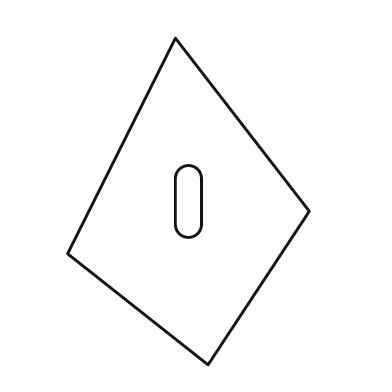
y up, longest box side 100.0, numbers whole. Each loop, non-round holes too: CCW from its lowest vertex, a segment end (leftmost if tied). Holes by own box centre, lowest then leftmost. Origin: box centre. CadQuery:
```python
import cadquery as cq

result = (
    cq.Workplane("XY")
    .moveTo(6.0, -50.0)
    .lineTo(37.0, -3.0)
    .lineTo(-4.0, 50.0)
    .lineTo(-37.0, -16.0)
    .close()
    .moveTo(-4.0, -7.0)
    .threePointArc((0.0, -11.0), (4.0, -7.0))
    .lineTo(4.0, 7.0)
    .threePointArc((0.0, 11.0), (-4.0, 7.0))
    .close()
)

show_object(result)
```